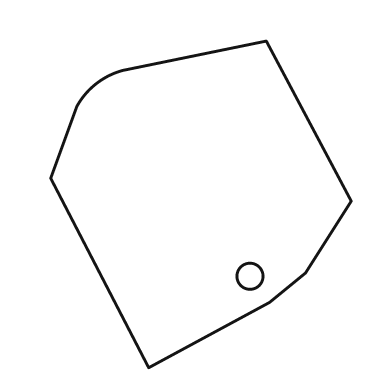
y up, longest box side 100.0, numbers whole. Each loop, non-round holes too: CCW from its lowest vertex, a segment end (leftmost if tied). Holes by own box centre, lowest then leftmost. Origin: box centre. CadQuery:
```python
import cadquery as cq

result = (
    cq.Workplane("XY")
    .moveTo(-16.0, -50.0)
    .lineTo(21.0, -30.0)
    .lineTo(32.0, -21.0)
    .lineTo(46.0, 1.0)
    .lineTo(20.0, 50.0)
    .lineTo(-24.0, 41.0)
    .threePointArc((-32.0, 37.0), (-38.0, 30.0))
    .lineTo(-46.0, 8.0)
    .close()
    .moveTo(15.0, -22.0)
    .circle(4.0)
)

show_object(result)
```